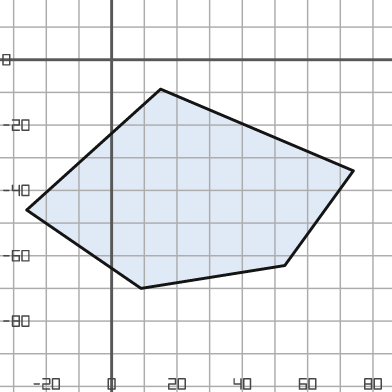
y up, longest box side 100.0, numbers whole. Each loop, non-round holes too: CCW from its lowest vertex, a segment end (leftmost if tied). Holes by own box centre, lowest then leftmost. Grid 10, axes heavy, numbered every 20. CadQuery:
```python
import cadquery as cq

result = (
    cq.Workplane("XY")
    .moveTo(9.0, -70.0)
    .lineTo(53.0, -63.0)
    .lineTo(74.0, -34.0)
    .lineTo(15.0, -9.0)
    .lineTo(-26.0, -46.0)
    .close()
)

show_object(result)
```